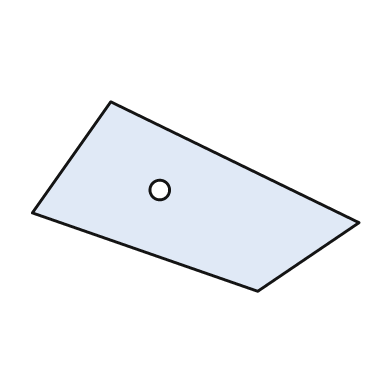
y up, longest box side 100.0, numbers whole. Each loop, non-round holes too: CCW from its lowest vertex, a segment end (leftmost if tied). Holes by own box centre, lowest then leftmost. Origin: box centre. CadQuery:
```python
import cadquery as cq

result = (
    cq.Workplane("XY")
    .moveTo(19.0, -29.0)
    .lineTo(50.0, -8.0)
    .lineTo(-26.0, 29.0)
    .lineTo(-50.0, -5.0)
    .close()
    .moveTo(-11.0, 2.0)
    .circle(3.0)
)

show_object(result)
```